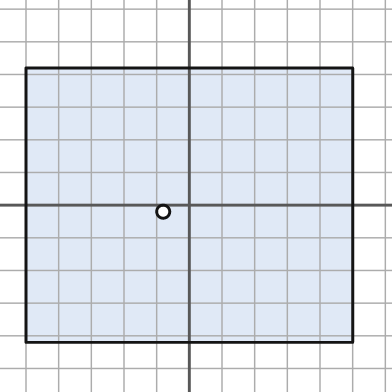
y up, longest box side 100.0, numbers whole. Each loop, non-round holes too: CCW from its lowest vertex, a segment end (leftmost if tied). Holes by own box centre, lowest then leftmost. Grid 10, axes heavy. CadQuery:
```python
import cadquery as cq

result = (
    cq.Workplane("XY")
    .moveTo(-50.0, -42.0)
    .lineTo(50.0, -42.0)
    .lineTo(50.0, 42.0)
    .lineTo(-50.0, 42.0)
    .close()
    .moveTo(-8.0, -2.0)
    .circle(2.0)
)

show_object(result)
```